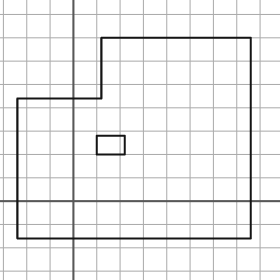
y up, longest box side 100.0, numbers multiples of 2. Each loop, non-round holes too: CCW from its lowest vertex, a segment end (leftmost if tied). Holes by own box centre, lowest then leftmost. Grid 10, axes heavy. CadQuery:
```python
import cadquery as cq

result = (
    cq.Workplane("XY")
    .moveTo(-24.0, -16.0)
    .lineTo(76.0, -16.0)
    .lineTo(76.0, 70.0)
    .lineTo(12.0, 70.0)
    .lineTo(12.0, 44.0)
    .lineTo(-24.0, 44.0)
    .close()
    .moveTo(10.0, 20.0)
    .lineTo(22.0, 20.0)
    .lineTo(22.0, 28.0)
    .lineTo(10.0, 28.0)
    .close()
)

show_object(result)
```